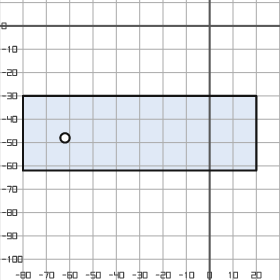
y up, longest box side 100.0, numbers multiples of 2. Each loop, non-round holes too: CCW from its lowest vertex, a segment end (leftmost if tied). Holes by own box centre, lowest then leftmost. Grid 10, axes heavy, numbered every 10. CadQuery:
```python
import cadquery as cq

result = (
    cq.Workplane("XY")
    .moveTo(-80.0, -62.0)
    .lineTo(20.0, -62.0)
    .lineTo(20.0, -30.0)
    .lineTo(-80.0, -30.0)
    .close()
    .moveTo(-62.0, -48.0)
    .circle(2.0)
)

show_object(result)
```